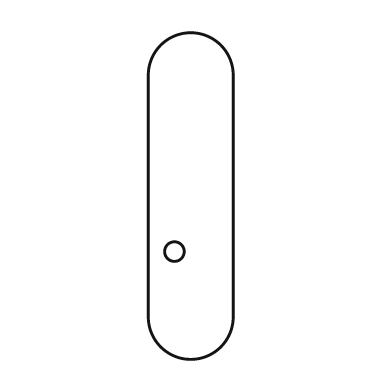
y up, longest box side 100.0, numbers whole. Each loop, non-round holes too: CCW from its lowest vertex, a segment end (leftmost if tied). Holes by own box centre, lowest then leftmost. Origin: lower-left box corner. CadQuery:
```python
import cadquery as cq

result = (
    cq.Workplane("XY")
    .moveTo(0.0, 13.0)
    .threePointArc((13.0, 0.0), (26.0, 13.0))
    .lineTo(26.0, 87.0)
    .threePointArc((13.0, 100.0), (0.0, 87.0))
    .close()
    .moveTo(8.0, 33.0)
    .circle(3.0)
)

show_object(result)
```